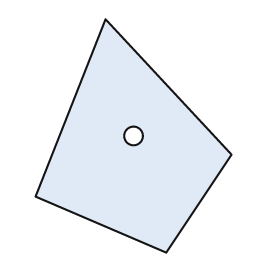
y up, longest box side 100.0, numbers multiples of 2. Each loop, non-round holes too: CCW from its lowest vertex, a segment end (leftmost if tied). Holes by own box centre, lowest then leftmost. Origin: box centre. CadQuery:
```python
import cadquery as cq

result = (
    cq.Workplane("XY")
    .moveTo(14.0, -50.0)
    .lineTo(42.0, -8.0)
    .lineTo(-12.0, 50.0)
    .lineTo(-42.0, -26.0)
    .close()
    .moveTo(0.0, 0.0)
    .circle(4.0)
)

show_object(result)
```